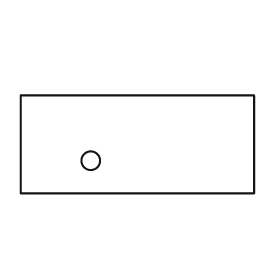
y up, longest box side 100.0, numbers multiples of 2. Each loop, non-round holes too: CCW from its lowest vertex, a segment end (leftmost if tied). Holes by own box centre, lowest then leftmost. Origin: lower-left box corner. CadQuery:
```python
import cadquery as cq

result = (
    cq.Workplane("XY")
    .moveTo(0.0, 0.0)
    .lineTo(100.0, 0.0)
    .lineTo(100.0, 42.0)
    .lineTo(0.0, 42.0)
    .close()
    .moveTo(30.0, 14.0)
    .circle(4.0)
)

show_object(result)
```